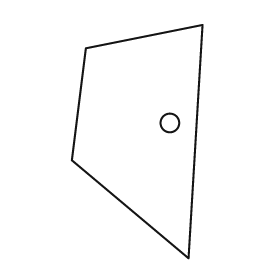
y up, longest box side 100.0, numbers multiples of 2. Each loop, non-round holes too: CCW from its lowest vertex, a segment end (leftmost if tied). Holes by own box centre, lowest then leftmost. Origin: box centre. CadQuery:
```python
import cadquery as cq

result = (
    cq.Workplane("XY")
    .moveTo(22.0, -50.0)
    .lineTo(28.0, 50.0)
    .lineTo(-22.0, 40.0)
    .lineTo(-28.0, -8.0)
    .close()
    .moveTo(14.0, 8.0)
    .circle(4.0)
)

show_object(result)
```